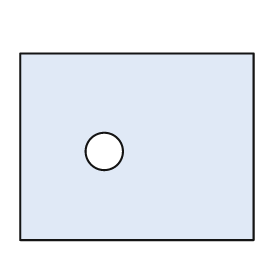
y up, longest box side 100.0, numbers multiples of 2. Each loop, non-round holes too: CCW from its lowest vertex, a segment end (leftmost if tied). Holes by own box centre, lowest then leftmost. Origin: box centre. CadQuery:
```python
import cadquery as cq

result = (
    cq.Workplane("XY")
    .moveTo(-50.0, -40.0)
    .lineTo(50.0, -40.0)
    .lineTo(50.0, 40.0)
    .lineTo(-50.0, 40.0)
    .close()
    .moveTo(-14.0, -2.0)
    .circle(8.0)
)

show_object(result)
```